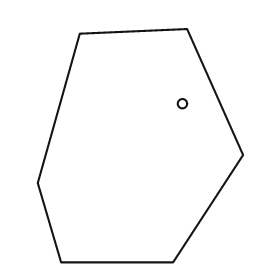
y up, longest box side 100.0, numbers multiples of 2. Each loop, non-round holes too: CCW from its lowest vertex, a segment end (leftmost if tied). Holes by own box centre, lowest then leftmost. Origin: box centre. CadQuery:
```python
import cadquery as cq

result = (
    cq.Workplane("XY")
    .moveTo(-34.0, -50.0)
    .lineTo(14.0, -50.0)
    .lineTo(44.0, -4.0)
    .lineTo(20.0, 50.0)
    .lineTo(-26.0, 48.0)
    .lineTo(-44.0, -16.0)
    .close()
    .moveTo(18.0, 18.0)
    .circle(2.0)
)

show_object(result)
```